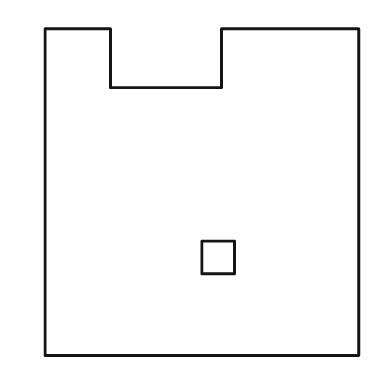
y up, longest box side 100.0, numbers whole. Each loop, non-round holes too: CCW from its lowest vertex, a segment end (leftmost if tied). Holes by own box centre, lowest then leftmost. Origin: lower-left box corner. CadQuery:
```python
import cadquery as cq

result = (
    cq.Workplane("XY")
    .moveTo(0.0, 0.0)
    .lineTo(96.0, 0.0)
    .lineTo(96.0, 100.0)
    .lineTo(54.0, 100.0)
    .lineTo(54.0, 82.0)
    .lineTo(20.0, 82.0)
    .lineTo(20.0, 100.0)
    .lineTo(0.0, 100.0)
    .close()
    .moveTo(48.0, 25.0)
    .lineTo(58.0, 25.0)
    .lineTo(58.0, 35.0)
    .lineTo(48.0, 35.0)
    .close()
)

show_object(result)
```